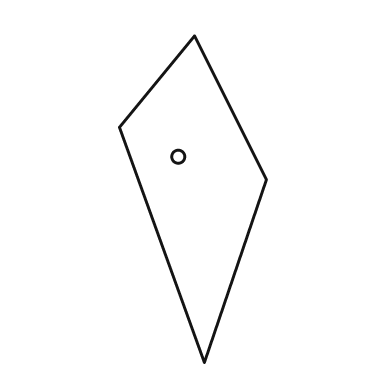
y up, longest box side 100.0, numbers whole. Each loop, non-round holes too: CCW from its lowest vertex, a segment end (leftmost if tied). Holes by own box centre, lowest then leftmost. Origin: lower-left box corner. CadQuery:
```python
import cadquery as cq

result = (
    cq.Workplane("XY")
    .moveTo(26.0, 0.0)
    .lineTo(45.0, 56.0)
    .lineTo(23.0, 100.0)
    .lineTo(0.0, 72.0)
    .close()
    .moveTo(18.0, 63.0)
    .circle(2.0)
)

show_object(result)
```